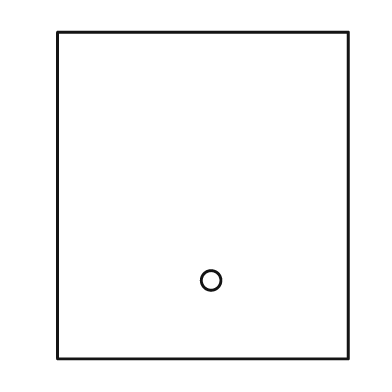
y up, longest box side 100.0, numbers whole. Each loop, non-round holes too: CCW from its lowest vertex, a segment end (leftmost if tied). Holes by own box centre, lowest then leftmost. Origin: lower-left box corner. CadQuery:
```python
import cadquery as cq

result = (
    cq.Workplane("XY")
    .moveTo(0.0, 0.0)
    .lineTo(89.0, 0.0)
    .lineTo(89.0, 100.0)
    .lineTo(0.0, 100.0)
    .close()
    .moveTo(47.0, 24.0)
    .circle(3.0)
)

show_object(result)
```